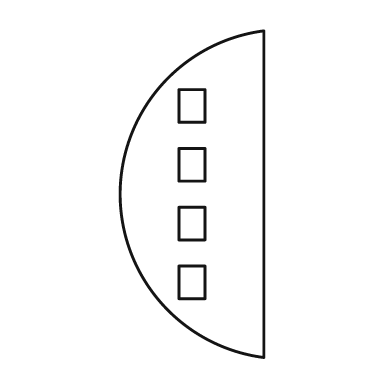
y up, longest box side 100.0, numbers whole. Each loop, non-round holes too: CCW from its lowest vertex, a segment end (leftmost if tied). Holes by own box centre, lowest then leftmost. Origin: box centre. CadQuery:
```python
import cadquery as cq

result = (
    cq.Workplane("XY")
    .moveTo(22.0, -50.0)
    .lineTo(22.0, 50.0)
    .threePointArc((-22.0, 0.0), (22.0, -50.0))
    .close()
    .moveTo(-4.0, -32.0)
    .lineTo(4.0, -32.0)
    .lineTo(4.0, -22.0)
    .lineTo(-4.0, -22.0)
    .close()
    .moveTo(-4.0, -14.0)
    .lineTo(4.0, -14.0)
    .lineTo(4.0, -4.0)
    .lineTo(-4.0, -4.0)
    .close()
    .moveTo(-4.0, 4.0)
    .lineTo(4.0, 4.0)
    .lineTo(4.0, 14.0)
    .lineTo(-4.0, 14.0)
    .close()
    .moveTo(-4.0, 22.0)
    .lineTo(4.0, 22.0)
    .lineTo(4.0, 32.0)
    .lineTo(-4.0, 32.0)
    .close()
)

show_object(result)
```